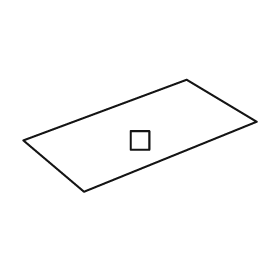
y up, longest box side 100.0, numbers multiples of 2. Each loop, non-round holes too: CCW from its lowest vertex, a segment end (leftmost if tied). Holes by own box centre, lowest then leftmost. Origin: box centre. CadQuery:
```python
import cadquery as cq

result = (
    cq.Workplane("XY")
    .moveTo(-24.0, -24.0)
    .lineTo(50.0, 6.0)
    .lineTo(20.0, 24.0)
    .lineTo(-50.0, -2.0)
    .close()
    .moveTo(-4.0, -6.0)
    .lineTo(4.0, -6.0)
    .lineTo(4.0, 2.0)
    .lineTo(-4.0, 2.0)
    .close()
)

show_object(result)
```